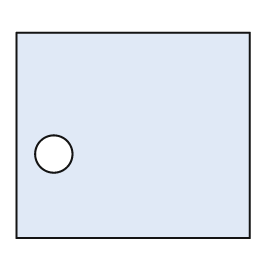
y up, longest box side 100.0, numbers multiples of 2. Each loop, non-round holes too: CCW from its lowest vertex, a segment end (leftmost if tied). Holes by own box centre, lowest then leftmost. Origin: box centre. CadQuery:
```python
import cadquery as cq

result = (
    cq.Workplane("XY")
    .moveTo(-50.0, -44.0)
    .lineTo(50.0, -44.0)
    .lineTo(50.0, 44.0)
    .lineTo(-50.0, 44.0)
    .close()
    .moveTo(-34.0, -8.0)
    .circle(8.0)
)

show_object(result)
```